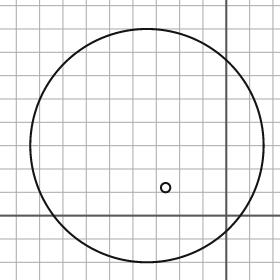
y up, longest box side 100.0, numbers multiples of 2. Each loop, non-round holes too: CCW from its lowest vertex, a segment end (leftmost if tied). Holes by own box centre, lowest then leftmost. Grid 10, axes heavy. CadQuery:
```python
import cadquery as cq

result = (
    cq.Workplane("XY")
    .moveTo(-34.0, 30.0)
    .circle(50.0)
    .moveTo(-26.0, 12.0)
    .circle(2.0)
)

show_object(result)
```